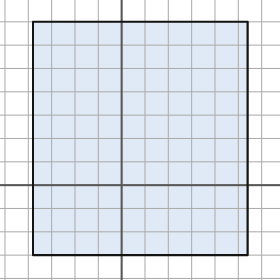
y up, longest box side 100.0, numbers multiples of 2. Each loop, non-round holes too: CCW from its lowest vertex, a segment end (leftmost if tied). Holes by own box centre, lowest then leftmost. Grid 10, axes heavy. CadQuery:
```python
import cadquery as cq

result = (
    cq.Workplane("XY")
    .moveTo(-38.0, -30.0)
    .lineTo(54.0, -30.0)
    .lineTo(54.0, 70.0)
    .lineTo(-38.0, 70.0)
    .close()
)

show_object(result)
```